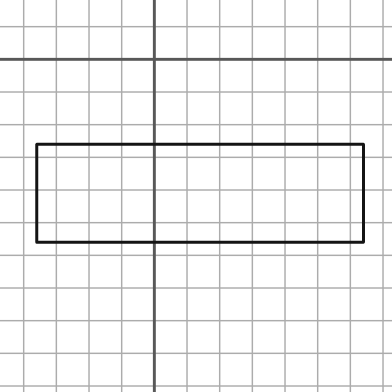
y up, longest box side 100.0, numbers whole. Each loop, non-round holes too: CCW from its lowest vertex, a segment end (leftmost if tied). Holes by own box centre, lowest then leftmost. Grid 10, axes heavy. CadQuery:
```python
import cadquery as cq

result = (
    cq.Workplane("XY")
    .moveTo(-36.0, -56.0)
    .lineTo(64.0, -56.0)
    .lineTo(64.0, -26.0)
    .lineTo(-36.0, -26.0)
    .close()
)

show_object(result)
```